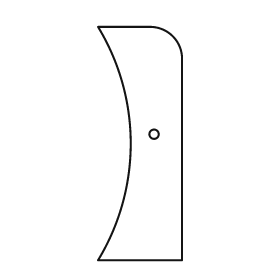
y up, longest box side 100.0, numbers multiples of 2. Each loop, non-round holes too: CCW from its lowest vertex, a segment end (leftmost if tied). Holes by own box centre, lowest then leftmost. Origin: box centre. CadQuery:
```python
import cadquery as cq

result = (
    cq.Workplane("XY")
    .moveTo(-18.0, -50.0)
    .lineTo(18.0, -50.0)
    .lineTo(18.0, 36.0)
    .threePointArc((14.0, 46.0), (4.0, 50.0))
    .lineTo(-18.0, 50.0)
    .threePointArc((-4.0, 0.0), (-18.0, -50.0))
    .close()
    .moveTo(6.0, 4.0)
    .circle(2.0)
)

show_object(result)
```